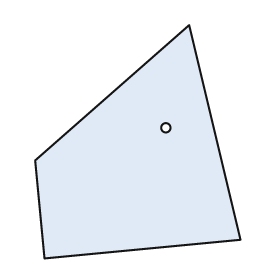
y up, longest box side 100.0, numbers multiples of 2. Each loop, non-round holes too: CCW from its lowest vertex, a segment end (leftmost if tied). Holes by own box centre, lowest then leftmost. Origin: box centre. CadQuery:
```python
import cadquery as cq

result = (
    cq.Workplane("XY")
    .moveTo(-40.0, -50.0)
    .lineTo(44.0, -42.0)
    .lineTo(22.0, 50.0)
    .lineTo(-44.0, -8.0)
    .close()
    .moveTo(12.0, 6.0)
    .circle(2.0)
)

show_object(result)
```